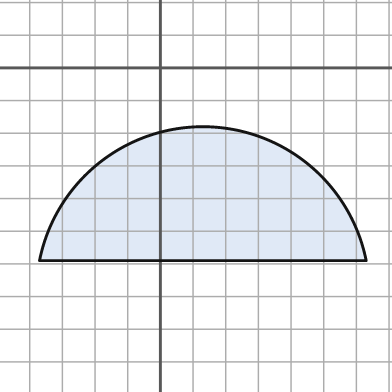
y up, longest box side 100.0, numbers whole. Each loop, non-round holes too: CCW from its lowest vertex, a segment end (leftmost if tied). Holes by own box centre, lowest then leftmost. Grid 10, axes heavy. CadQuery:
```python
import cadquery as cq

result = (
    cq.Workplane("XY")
    .moveTo(-37.0, -59.0)
    .lineTo(63.0, -59.0)
    .threePointArc((13.0, -18.0), (-37.0, -59.0))
    .close()
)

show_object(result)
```